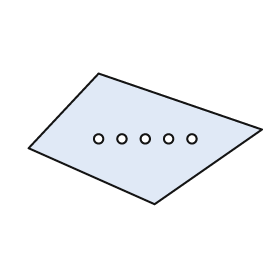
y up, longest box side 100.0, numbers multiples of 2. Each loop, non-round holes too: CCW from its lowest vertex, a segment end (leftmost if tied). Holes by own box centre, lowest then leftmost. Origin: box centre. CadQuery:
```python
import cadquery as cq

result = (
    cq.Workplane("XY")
    .moveTo(4.0, -28.0)
    .lineTo(50.0, 4.0)
    .lineTo(-20.0, 28.0)
    .lineTo(-50.0, -4.0)
    .close()
    .moveTo(-20.0, 0.0)
    .circle(2.0)
    .moveTo(-10.0, 0.0)
    .circle(2.0)
    .moveTo(0.0, 0.0)
    .circle(2.0)
    .moveTo(10.0, 0.0)
    .circle(2.0)
    .moveTo(20.0, 0.0)
    .circle(2.0)
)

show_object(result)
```